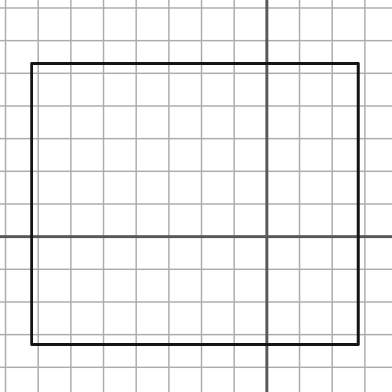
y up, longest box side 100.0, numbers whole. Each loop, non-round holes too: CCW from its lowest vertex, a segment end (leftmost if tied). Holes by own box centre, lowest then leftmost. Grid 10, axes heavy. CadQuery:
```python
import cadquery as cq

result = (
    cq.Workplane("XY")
    .moveTo(-72.0, -33.0)
    .lineTo(28.0, -33.0)
    .lineTo(28.0, 53.0)
    .lineTo(-72.0, 53.0)
    .close()
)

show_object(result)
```